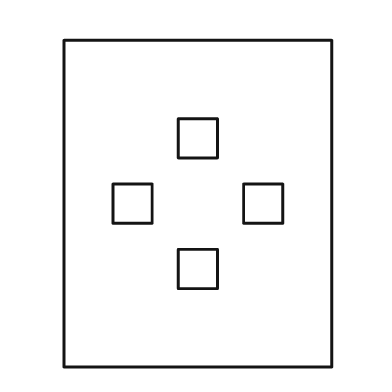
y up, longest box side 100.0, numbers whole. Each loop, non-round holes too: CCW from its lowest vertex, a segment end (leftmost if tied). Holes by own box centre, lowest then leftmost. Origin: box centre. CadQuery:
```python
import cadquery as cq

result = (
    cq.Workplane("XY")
    .moveTo(-41.0, -50.0)
    .lineTo(41.0, -50.0)
    .lineTo(41.0, 50.0)
    .lineTo(-41.0, 50.0)
    .close()
    .moveTo(-6.0, -26.0)
    .lineTo(6.0, -26.0)
    .lineTo(6.0, -14.0)
    .lineTo(-6.0, -14.0)
    .close()
    .moveTo(-26.0, -6.0)
    .lineTo(-14.0, -6.0)
    .lineTo(-14.0, 6.0)
    .lineTo(-26.0, 6.0)
    .close()
    .moveTo(14.0, -6.0)
    .lineTo(26.0, -6.0)
    .lineTo(26.0, 6.0)
    .lineTo(14.0, 6.0)
    .close()
    .moveTo(-6.0, 14.0)
    .lineTo(6.0, 14.0)
    .lineTo(6.0, 26.0)
    .lineTo(-6.0, 26.0)
    .close()
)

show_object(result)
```